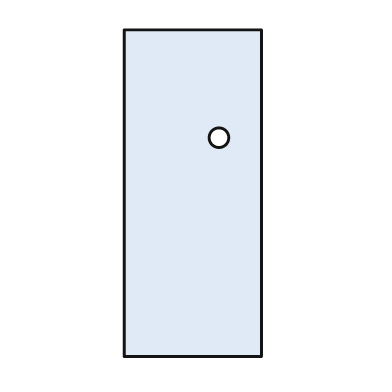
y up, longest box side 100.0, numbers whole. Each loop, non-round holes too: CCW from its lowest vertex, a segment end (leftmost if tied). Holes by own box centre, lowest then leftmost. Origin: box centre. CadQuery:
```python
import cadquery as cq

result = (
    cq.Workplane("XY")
    .moveTo(-21.0, -50.0)
    .lineTo(21.0, -50.0)
    .lineTo(21.0, 50.0)
    .lineTo(-21.0, 50.0)
    .close()
    .moveTo(8.0, 17.0)
    .circle(3.0)
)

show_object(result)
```